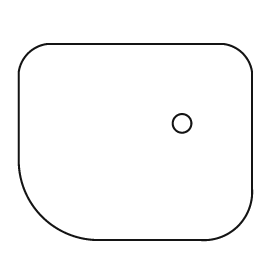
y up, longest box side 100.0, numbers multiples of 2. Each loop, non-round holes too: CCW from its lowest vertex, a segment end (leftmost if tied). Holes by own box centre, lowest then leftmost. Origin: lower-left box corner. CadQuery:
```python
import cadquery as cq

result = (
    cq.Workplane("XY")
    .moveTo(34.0, 0.0)
    .lineTo(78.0, 0.0)
    .threePointArc((94.0, 6.0), (100.0, 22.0))
    .lineTo(100.0, 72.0)
    .threePointArc((96.0, 80.0), (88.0, 84.0))
    .lineTo(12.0, 84.0)
    .threePointArc((4.0, 80.0), (0.0, 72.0))
    .lineTo(0.0, 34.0)
    .threePointArc((10.0, 10.0), (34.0, 0.0))
    .close()
    .moveTo(70.0, 50.0)
    .circle(4.0)
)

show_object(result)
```